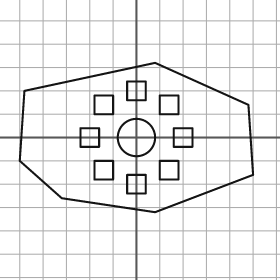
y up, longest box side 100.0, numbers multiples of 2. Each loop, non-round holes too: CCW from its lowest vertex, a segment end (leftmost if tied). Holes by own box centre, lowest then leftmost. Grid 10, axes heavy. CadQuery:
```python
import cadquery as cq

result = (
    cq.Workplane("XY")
    .moveTo(8.0, -32.0)
    .lineTo(50.0, -16.0)
    .lineTo(48.0, 14.0)
    .lineTo(8.0, 32.0)
    .lineTo(-48.0, 20.0)
    .lineTo(-50.0, -10.0)
    .lineTo(-32.0, -26.0)
    .close()
    .moveTo(-4.0, -24.0)
    .lineTo(4.0, -24.0)
    .lineTo(4.0, -16.0)
    .lineTo(-4.0, -16.0)
    .close()
    .moveTo(-18.0, -18.0)
    .lineTo(-10.0, -18.0)
    .lineTo(-10.0, -10.0)
    .lineTo(-18.0, -10.0)
    .close()
    .moveTo(10.0, -18.0)
    .lineTo(18.0, -18.0)
    .lineTo(18.0, -10.0)
    .lineTo(10.0, -10.0)
    .close()
    .moveTo(-24.0, -4.0)
    .lineTo(-16.0, -4.0)
    .lineTo(-16.0, 4.0)
    .lineTo(-24.0, 4.0)
    .close()
    .moveTo(0.0, 0.0)
    .circle(8.0)
    .moveTo(16.0, -4.0)
    .lineTo(24.0, -4.0)
    .lineTo(24.0, 4.0)
    .lineTo(16.0, 4.0)
    .close()
    .moveTo(-18.0, 10.0)
    .lineTo(-10.0, 10.0)
    .lineTo(-10.0, 18.0)
    .lineTo(-18.0, 18.0)
    .close()
    .moveTo(10.0, 10.0)
    .lineTo(18.0, 10.0)
    .lineTo(18.0, 18.0)
    .lineTo(10.0, 18.0)
    .close()
    .moveTo(-4.0, 16.0)
    .lineTo(4.0, 16.0)
    .lineTo(4.0, 24.0)
    .lineTo(-4.0, 24.0)
    .close()
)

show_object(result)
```